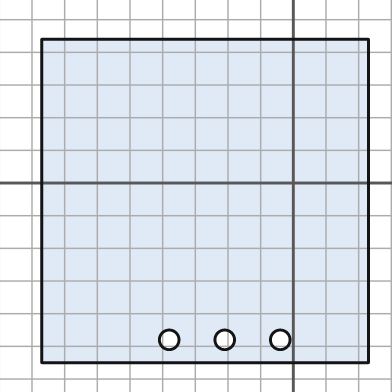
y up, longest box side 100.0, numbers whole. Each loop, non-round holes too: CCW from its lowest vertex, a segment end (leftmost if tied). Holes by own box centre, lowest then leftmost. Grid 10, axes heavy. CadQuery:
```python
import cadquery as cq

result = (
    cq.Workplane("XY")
    .moveTo(-77.0, -55.0)
    .lineTo(23.0, -55.0)
    .lineTo(23.0, 44.0)
    .lineTo(-77.0, 44.0)
    .close()
    .moveTo(-38.0, -48.0)
    .circle(3.0)
    .moveTo(-21.0, -48.0)
    .circle(3.0)
    .moveTo(-4.0, -48.0)
    .circle(3.0)
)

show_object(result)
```